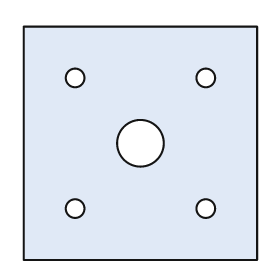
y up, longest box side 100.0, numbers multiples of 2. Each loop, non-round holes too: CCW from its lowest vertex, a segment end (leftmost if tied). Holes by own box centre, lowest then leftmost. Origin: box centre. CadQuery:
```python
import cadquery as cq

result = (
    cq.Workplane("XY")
    .moveTo(-50.0, -50.0)
    .lineTo(50.0, -50.0)
    .lineTo(50.0, 50.0)
    .lineTo(-50.0, 50.0)
    .close()
    .moveTo(-28.0, -28.0)
    .circle(4.0)
    .moveTo(28.0, -28.0)
    .circle(4.0)
    .moveTo(0.0, 0.0)
    .circle(10.0)
    .moveTo(-28.0, 28.0)
    .circle(4.0)
    .moveTo(28.0, 28.0)
    .circle(4.0)
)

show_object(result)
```